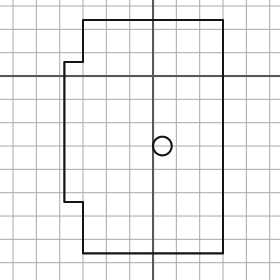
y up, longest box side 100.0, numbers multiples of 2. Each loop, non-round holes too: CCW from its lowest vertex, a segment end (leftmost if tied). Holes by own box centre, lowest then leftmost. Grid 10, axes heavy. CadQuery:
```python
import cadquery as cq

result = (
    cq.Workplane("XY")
    .moveTo(-30.0, -76.0)
    .lineTo(30.0, -76.0)
    .lineTo(30.0, 24.0)
    .lineTo(-30.0, 24.0)
    .lineTo(-30.0, 6.0)
    .lineTo(-38.0, 6.0)
    .lineTo(-38.0, -54.0)
    .lineTo(-30.0, -54.0)
    .close()
    .moveTo(4.0, -30.0)
    .circle(4.0)
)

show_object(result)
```